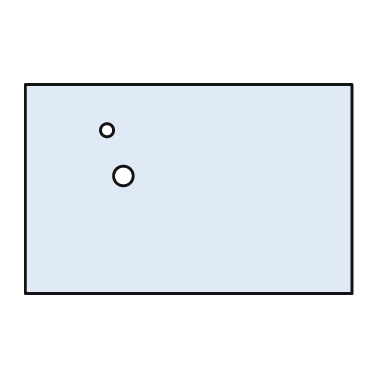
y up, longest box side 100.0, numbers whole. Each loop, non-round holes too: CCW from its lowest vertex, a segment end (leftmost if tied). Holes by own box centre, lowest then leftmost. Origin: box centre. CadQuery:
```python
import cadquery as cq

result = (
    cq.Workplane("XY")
    .moveTo(-50.0, -32.0)
    .lineTo(50.0, -32.0)
    .lineTo(50.0, 32.0)
    .lineTo(-50.0, 32.0)
    .close()
    .moveTo(-20.0, 4.0)
    .circle(3.0)
    .moveTo(-25.0, 18.0)
    .circle(2.0)
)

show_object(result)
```